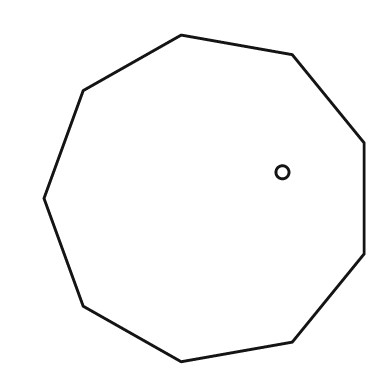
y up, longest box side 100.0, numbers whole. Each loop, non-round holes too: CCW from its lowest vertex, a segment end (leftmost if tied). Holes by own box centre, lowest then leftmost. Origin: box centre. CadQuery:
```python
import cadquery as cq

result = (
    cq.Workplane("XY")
    .moveTo(-7.0, -50.0)
    .lineTo(27.0, -44.0)
    .lineTo(49.0, -17.0)
    .lineTo(49.0, 17.0)
    .lineTo(27.0, 44.0)
    .lineTo(-7.0, 50.0)
    .lineTo(-37.0, 33.0)
    .lineTo(-49.0, 0.0)
    .lineTo(-37.0, -33.0)
    .close()
    .moveTo(24.0, 8.0)
    .circle(2.0)
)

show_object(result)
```